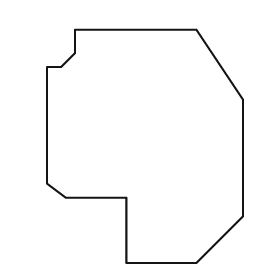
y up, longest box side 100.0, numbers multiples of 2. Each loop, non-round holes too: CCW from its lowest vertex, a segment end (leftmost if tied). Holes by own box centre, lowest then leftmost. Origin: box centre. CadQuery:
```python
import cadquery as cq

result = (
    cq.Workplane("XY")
    .moveTo(-8.0, -50.0)
    .lineTo(22.0, -50.0)
    .lineTo(42.0, -30.0)
    .lineTo(42.0, 20.0)
    .lineTo(22.0, 50.0)
    .lineTo(-30.0, 50.0)
    .lineTo(-30.0, 40.0)
    .lineTo(-36.0, 34.0)
    .lineTo(-42.0, 34.0)
    .lineTo(-42.0, -16.0)
    .lineTo(-34.0, -22.0)
    .lineTo(-8.0, -22.0)
    .close()
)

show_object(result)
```